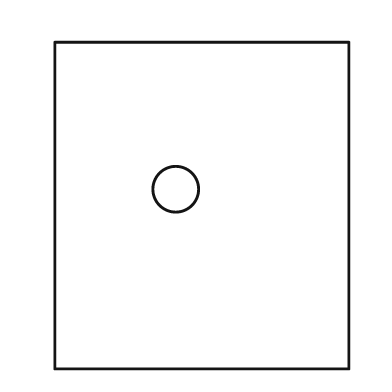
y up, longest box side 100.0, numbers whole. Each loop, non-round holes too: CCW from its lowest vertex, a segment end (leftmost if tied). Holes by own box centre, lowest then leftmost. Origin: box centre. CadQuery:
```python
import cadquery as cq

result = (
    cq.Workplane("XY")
    .moveTo(-45.0, -50.0)
    .lineTo(45.0, -50.0)
    .lineTo(45.0, 50.0)
    .lineTo(-45.0, 50.0)
    .close()
    .moveTo(-8.0, 5.0)
    .circle(7.0)
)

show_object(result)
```